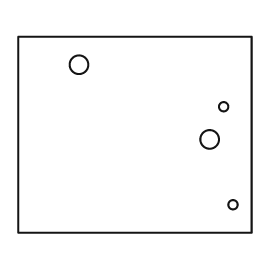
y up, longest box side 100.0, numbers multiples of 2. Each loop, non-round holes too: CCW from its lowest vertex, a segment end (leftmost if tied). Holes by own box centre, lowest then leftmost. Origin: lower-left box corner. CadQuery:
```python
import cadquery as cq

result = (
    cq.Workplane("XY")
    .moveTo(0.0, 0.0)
    .lineTo(100.0, 0.0)
    .lineTo(100.0, 84.0)
    .lineTo(0.0, 84.0)
    .close()
    .moveTo(92.0, 12.0)
    .circle(2.0)
    .moveTo(82.0, 40.0)
    .circle(4.0)
    .moveTo(88.0, 54.0)
    .circle(2.0)
    .moveTo(26.0, 72.0)
    .circle(4.0)
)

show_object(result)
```